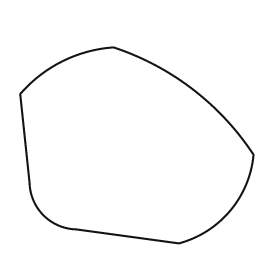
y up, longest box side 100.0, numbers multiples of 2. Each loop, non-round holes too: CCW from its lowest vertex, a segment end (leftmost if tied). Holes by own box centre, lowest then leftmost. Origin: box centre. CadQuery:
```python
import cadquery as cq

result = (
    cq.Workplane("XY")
    .moveTo(18.0, -42.0)
    .threePointArc((40.0, -28.0), (50.0, -4.0))
    .threePointArc((24.0, 24.0), (-10.0, 42.0))
    .threePointArc((-32.0, 36.0), (-50.0, 22.0))
    .lineTo(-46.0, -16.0)
    .threePointArc((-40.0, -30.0), (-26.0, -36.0))
    .close()
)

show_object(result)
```